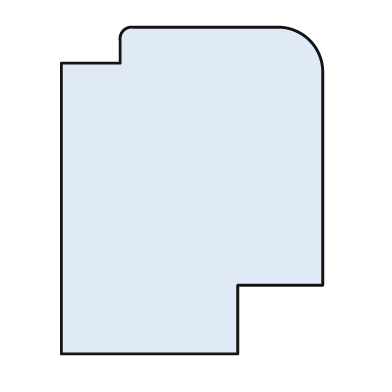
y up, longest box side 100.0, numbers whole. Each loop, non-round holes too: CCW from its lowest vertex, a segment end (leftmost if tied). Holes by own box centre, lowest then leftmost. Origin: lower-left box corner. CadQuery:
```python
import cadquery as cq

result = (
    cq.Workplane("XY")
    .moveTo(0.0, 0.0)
    .lineTo(54.0, 0.0)
    .lineTo(54.0, 21.0)
    .lineTo(80.0, 21.0)
    .lineTo(80.0, 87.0)
    .threePointArc((76.0, 96.0), (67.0, 100.0))
    .lineTo(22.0, 100.0)
    .threePointArc((19.0, 99.0), (18.0, 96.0))
    .lineTo(18.0, 89.0)
    .lineTo(0.0, 89.0)
    .close()
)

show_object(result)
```